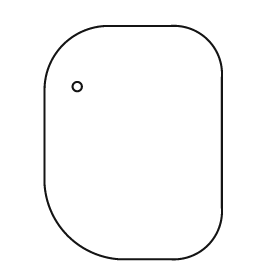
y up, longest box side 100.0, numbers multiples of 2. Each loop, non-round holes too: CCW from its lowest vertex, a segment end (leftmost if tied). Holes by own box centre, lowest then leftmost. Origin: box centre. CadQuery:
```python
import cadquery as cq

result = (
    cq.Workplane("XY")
    .moveTo(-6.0, -50.0)
    .lineTo(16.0, -50.0)
    .threePointArc((32.0, -44.0), (38.0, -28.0))
    .lineTo(38.0, 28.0)
    .threePointArc((32.0, 44.0), (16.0, 50.0))
    .lineTo(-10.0, 50.0)
    .threePointArc((-30.0, 42.0), (-38.0, 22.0))
    .lineTo(-38.0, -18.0)
    .threePointArc((-28.0, -40.0), (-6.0, -50.0))
    .close()
    .moveTo(-24.0, 24.0)
    .circle(2.0)
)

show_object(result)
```